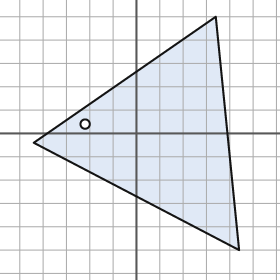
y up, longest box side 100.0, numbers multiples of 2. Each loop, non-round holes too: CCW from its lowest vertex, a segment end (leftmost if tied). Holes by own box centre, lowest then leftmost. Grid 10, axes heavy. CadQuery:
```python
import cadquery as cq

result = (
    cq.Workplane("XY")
    .moveTo(44.0, -50.0)
    .lineTo(34.0, 50.0)
    .lineTo(-44.0, -4.0)
    .close()
    .moveTo(-22.0, 4.0)
    .circle(2.0)
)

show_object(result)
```